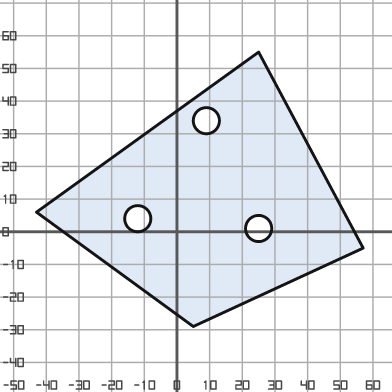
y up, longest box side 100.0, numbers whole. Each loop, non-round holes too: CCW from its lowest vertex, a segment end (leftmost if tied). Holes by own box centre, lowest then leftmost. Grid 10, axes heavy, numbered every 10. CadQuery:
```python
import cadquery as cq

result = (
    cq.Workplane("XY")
    .moveTo(5.0, -29.0)
    .lineTo(57.0, -5.0)
    .lineTo(25.0, 55.0)
    .lineTo(-43.0, 6.0)
    .close()
    .moveTo(25.0, 1.0)
    .circle(4.0)
    .moveTo(-12.0, 4.0)
    .circle(4.0)
    .moveTo(9.0, 34.0)
    .circle(4.0)
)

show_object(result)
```